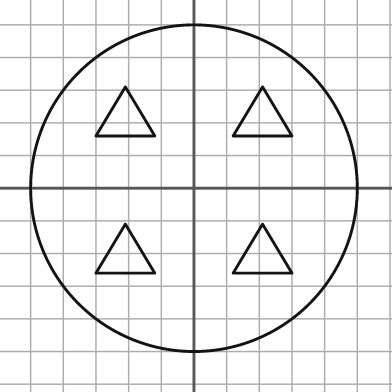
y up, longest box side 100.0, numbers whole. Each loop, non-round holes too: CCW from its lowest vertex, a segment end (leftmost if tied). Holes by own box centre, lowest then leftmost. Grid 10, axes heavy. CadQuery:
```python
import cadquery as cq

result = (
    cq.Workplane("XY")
    .moveTo(0.0, 0.0)
    .circle(50.0)
    .moveTo(-30.0, -26.0)
    .lineTo(-12.0, -26.0)
    .lineTo(-21.0, -11.0)
    .close()
    .moveTo(12.0, -26.0)
    .lineTo(30.0, -26.0)
    .lineTo(21.0, -11.0)
    .close()
    .moveTo(-30.0, 16.0)
    .lineTo(-12.0, 16.0)
    .lineTo(-21.0, 31.0)
    .close()
    .moveTo(12.0, 16.0)
    .lineTo(30.0, 16.0)
    .lineTo(21.0, 31.0)
    .close()
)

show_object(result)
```